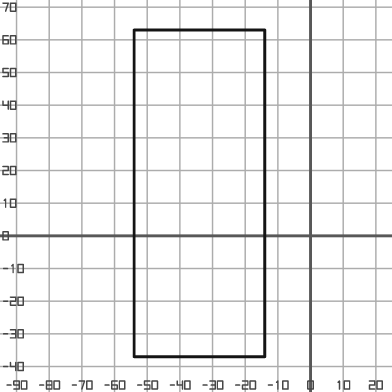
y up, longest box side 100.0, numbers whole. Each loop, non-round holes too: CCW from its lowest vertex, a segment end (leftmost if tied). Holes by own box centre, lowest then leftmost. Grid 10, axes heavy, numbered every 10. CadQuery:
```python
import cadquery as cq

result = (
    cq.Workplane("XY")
    .moveTo(-54.0, -37.0)
    .lineTo(-14.0, -37.0)
    .lineTo(-14.0, 63.0)
    .lineTo(-54.0, 63.0)
    .close()
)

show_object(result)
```